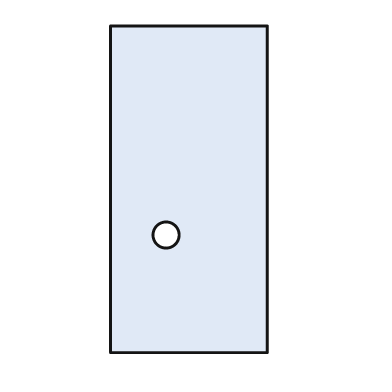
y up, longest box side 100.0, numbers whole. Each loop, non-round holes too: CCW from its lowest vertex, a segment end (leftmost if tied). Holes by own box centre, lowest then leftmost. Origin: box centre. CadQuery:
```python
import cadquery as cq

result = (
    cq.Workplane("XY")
    .moveTo(-24.0, -50.0)
    .lineTo(24.0, -50.0)
    .lineTo(24.0, 50.0)
    .lineTo(-24.0, 50.0)
    .close()
    .moveTo(-7.0, -14.0)
    .circle(4.0)
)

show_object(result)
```